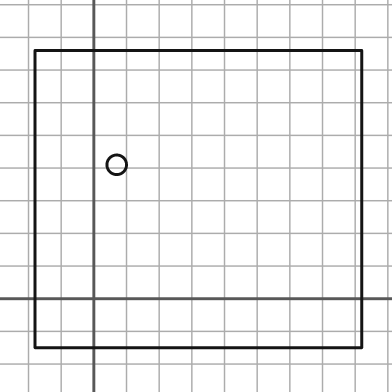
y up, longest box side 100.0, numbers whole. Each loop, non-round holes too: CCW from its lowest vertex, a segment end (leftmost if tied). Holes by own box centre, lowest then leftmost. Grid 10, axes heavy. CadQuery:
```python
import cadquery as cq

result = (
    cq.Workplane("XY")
    .moveTo(-18.0, -15.0)
    .lineTo(82.0, -15.0)
    .lineTo(82.0, 76.0)
    .lineTo(-18.0, 76.0)
    .close()
    .moveTo(7.0, 41.0)
    .circle(3.0)
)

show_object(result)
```